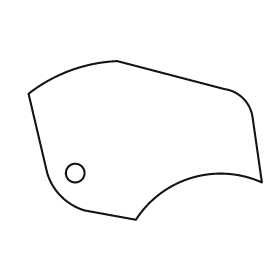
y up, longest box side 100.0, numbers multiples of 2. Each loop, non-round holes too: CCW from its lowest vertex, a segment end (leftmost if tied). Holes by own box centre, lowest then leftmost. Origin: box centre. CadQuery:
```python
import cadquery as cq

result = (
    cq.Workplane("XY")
    .moveTo(-4.0, -34.0)
    .threePointArc((20.0, -16.0), (50.0, -18.0))
    .lineTo(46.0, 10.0)
    .threePointArc((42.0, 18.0), (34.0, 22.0))
    .lineTo(-12.0, 34.0)
    .threePointArc((-32.0, 30.0), (-50.0, 20.0))
    .lineTo(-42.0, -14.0)
    .threePointArc((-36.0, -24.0), (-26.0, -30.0))
    .close()
    .moveTo(-30.0, -14.0)
    .circle(4.0)
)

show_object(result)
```